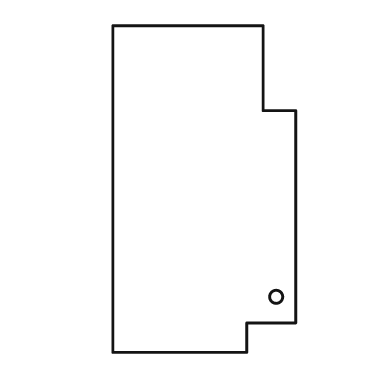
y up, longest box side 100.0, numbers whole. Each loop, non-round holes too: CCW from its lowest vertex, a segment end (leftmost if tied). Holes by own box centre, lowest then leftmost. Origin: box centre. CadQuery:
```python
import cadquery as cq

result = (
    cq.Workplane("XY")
    .moveTo(-28.0, -50.0)
    .lineTo(13.0, -50.0)
    .lineTo(13.0, -41.0)
    .lineTo(28.0, -41.0)
    .lineTo(28.0, 24.0)
    .lineTo(18.0, 24.0)
    .lineTo(18.0, 50.0)
    .lineTo(-28.0, 50.0)
    .close()
    .moveTo(22.0, -33.0)
    .circle(2.0)
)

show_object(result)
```